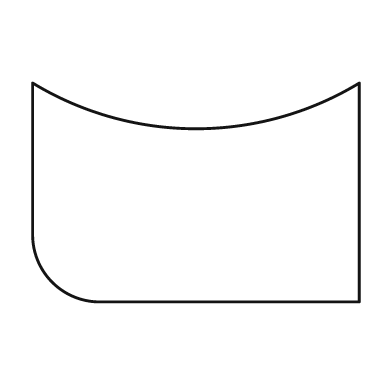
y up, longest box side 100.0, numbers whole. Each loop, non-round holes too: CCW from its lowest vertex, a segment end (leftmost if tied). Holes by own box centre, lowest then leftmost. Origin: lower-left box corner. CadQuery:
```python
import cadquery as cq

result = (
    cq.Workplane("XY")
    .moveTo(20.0, 0.0)
    .lineTo(100.0, 0.0)
    .lineTo(100.0, 67.0)
    .threePointArc((50.0, 53.0), (0.0, 67.0))
    .lineTo(0.0, 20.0)
    .threePointArc((6.0, 6.0), (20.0, 0.0))
    .close()
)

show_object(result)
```